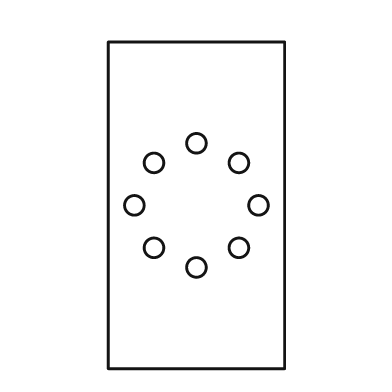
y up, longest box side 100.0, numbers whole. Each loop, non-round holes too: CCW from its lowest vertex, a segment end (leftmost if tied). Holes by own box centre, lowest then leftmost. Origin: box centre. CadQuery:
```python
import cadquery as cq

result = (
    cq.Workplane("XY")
    .moveTo(-27.0, -50.0)
    .lineTo(27.0, -50.0)
    .lineTo(27.0, 50.0)
    .lineTo(-27.0, 50.0)
    .close()
    .moveTo(0.0, -19.0)
    .circle(3.0)
    .moveTo(-13.0, -13.0)
    .circle(3.0)
    .moveTo(13.0, -13.0)
    .circle(3.0)
    .moveTo(-19.0, 0.0)
    .circle(3.0)
    .moveTo(19.0, 0.0)
    .circle(3.0)
    .moveTo(-13.0, 13.0)
    .circle(3.0)
    .moveTo(13.0, 13.0)
    .circle(3.0)
    .moveTo(0.0, 19.0)
    .circle(3.0)
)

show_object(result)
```